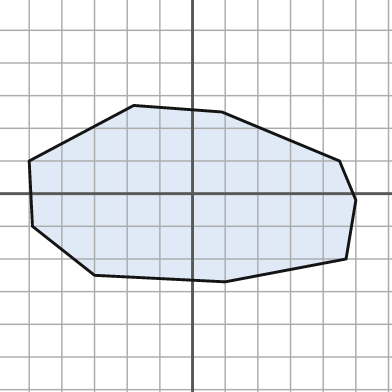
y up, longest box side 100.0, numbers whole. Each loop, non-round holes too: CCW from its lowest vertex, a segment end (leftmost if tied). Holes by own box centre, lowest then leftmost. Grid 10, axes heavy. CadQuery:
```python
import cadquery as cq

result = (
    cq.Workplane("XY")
    .moveTo(10.0, -27.0)
    .lineTo(47.0, -20.0)
    .lineTo(50.0, -2.0)
    .lineTo(45.0, 10.0)
    .lineTo(9.0, 25.0)
    .lineTo(-18.0, 27.0)
    .lineTo(-50.0, 10.0)
    .lineTo(-49.0, -10.0)
    .lineTo(-30.0, -25.0)
    .close()
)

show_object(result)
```